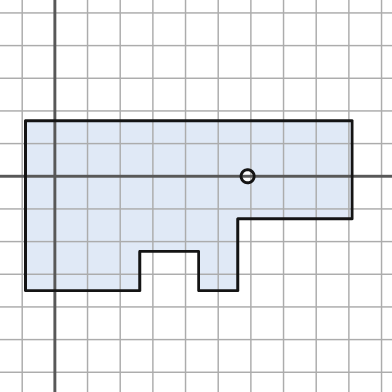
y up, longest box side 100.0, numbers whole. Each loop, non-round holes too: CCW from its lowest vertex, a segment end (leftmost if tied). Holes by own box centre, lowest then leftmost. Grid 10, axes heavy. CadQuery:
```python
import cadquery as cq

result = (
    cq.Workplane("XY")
    .moveTo(-9.0, -35.0)
    .lineTo(26.0, -35.0)
    .lineTo(26.0, -23.0)
    .lineTo(44.0, -23.0)
    .lineTo(44.0, -35.0)
    .lineTo(56.0, -35.0)
    .lineTo(56.0, -13.0)
    .lineTo(91.0, -13.0)
    .lineTo(91.0, 17.0)
    .lineTo(-9.0, 17.0)
    .close()
    .moveTo(59.0, 0.0)
    .circle(2.0)
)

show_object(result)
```